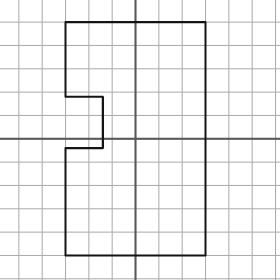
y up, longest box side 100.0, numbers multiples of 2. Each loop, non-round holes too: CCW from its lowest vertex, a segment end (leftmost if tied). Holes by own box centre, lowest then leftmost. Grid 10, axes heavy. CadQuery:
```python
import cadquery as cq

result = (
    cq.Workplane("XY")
    .moveTo(-30.0, -50.0)
    .lineTo(30.0, -50.0)
    .lineTo(30.0, 50.0)
    .lineTo(-30.0, 50.0)
    .lineTo(-30.0, 18.0)
    .lineTo(-14.0, 18.0)
    .lineTo(-14.0, -4.0)
    .lineTo(-30.0, -4.0)
    .close()
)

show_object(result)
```